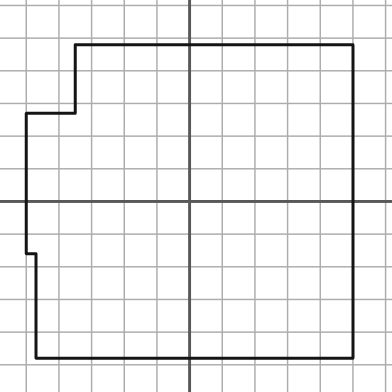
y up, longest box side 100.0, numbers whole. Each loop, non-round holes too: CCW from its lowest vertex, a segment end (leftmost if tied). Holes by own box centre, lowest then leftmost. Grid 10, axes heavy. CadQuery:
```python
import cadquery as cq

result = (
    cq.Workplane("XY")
    .moveTo(-47.0, -48.0)
    .lineTo(50.0, -48.0)
    .lineTo(50.0, 48.0)
    .lineTo(-35.0, 48.0)
    .lineTo(-35.0, 27.0)
    .lineTo(-50.0, 27.0)
    .lineTo(-50.0, -16.0)
    .lineTo(-47.0, -16.0)
    .close()
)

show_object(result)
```